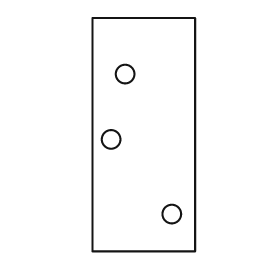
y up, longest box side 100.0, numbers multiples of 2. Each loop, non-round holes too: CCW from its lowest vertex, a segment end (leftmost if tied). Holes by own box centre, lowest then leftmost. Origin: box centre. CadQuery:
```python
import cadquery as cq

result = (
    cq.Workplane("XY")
    .moveTo(-22.0, -50.0)
    .lineTo(22.0, -50.0)
    .lineTo(22.0, 50.0)
    .lineTo(-22.0, 50.0)
    .close()
    .moveTo(12.0, -34.0)
    .circle(4.0)
    .moveTo(-14.0, -2.0)
    .circle(4.0)
    .moveTo(-8.0, 26.0)
    .circle(4.0)
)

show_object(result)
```